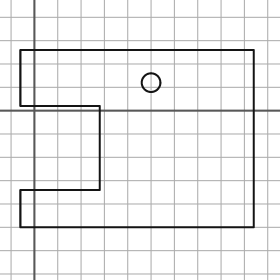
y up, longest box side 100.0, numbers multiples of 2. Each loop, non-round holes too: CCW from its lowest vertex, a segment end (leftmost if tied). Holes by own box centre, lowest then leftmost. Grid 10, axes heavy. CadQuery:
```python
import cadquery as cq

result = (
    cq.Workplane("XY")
    .moveTo(-6.0, -50.0)
    .lineTo(94.0, -50.0)
    .lineTo(94.0, 26.0)
    .lineTo(-6.0, 26.0)
    .lineTo(-6.0, 2.0)
    .lineTo(28.0, 2.0)
    .lineTo(28.0, -34.0)
    .lineTo(-6.0, -34.0)
    .close()
    .moveTo(50.0, 12.0)
    .circle(4.0)
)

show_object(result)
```